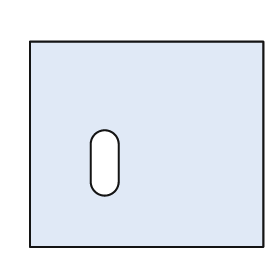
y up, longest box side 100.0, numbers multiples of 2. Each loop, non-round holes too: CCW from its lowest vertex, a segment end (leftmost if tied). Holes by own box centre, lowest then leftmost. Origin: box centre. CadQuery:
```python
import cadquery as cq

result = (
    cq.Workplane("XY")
    .moveTo(-50.0, -44.0)
    .lineTo(50.0, -44.0)
    .lineTo(50.0, 44.0)
    .lineTo(-50.0, 44.0)
    .close()
    .moveTo(-24.0, -16.0)
    .threePointArc((-18.0, -22.0), (-12.0, -16.0))
    .lineTo(-12.0, 0.0)
    .threePointArc((-18.0, 6.0), (-24.0, 0.0))
    .close()
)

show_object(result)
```